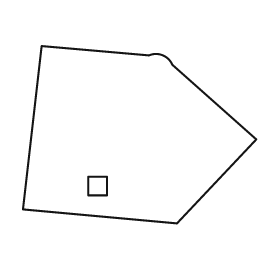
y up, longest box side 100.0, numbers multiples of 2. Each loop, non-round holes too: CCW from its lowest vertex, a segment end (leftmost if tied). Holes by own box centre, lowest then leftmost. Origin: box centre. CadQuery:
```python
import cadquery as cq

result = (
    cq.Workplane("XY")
    .moveTo(16.0, -38.0)
    .lineTo(50.0, -2.0)
    .lineTo(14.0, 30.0)
    .threePointArc((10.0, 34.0), (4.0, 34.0))
    .lineTo(-42.0, 38.0)
    .lineTo(-50.0, -32.0)
    .close()
    .moveTo(-22.0, -26.0)
    .lineTo(-14.0, -26.0)
    .lineTo(-14.0, -18.0)
    .lineTo(-22.0, -18.0)
    .close()
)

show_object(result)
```